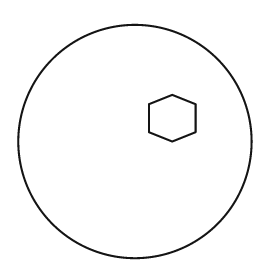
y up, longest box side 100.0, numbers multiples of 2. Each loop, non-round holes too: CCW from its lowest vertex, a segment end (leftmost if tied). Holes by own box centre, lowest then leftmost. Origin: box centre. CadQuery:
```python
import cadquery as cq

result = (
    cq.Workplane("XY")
    .moveTo(0.0, 0.0)
    .circle(50.0)
    .moveTo(16.0, 0.0)
    .lineTo(26.0, 4.0)
    .lineTo(26.0, 16.0)
    .lineTo(16.0, 20.0)
    .lineTo(6.0, 16.0)
    .lineTo(6.0, 4.0)
    .close()
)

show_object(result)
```